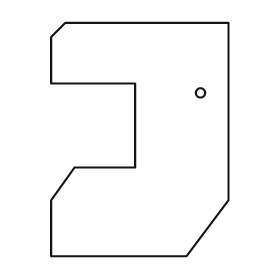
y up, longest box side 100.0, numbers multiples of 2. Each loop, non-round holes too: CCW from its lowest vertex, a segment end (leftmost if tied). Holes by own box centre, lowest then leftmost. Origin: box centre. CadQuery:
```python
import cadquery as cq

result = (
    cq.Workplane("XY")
    .moveTo(-38.0, -50.0)
    .lineTo(20.0, -50.0)
    .lineTo(38.0, -26.0)
    .lineTo(38.0, 50.0)
    .lineTo(-32.0, 50.0)
    .lineTo(-38.0, 44.0)
    .lineTo(-38.0, 24.0)
    .lineTo(-2.0, 24.0)
    .lineTo(-2.0, -12.0)
    .lineTo(-28.0, -12.0)
    .lineTo(-38.0, -26.0)
    .close()
    .moveTo(26.0, 20.0)
    .circle(2.0)
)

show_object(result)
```